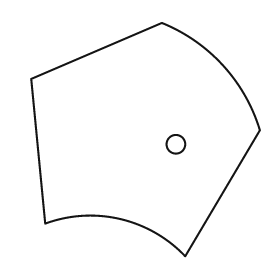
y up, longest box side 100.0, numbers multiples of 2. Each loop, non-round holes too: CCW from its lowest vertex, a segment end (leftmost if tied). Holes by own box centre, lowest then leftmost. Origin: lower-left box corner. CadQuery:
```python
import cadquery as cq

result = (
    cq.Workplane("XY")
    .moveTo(66.0, 0.0)
    .lineTo(98.0, 54.0)
    .threePointArc((82.0, 82.0), (56.0, 100.0))
    .lineTo(0.0, 76.0)
    .lineTo(6.0, 14.0)
    .threePointArc((38.0, 16.0), (66.0, 0.0))
    .close()
    .moveTo(62.0, 48.0)
    .circle(4.0)
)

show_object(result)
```